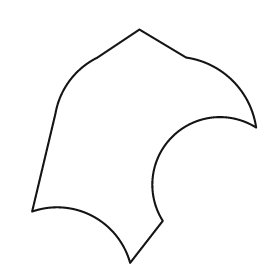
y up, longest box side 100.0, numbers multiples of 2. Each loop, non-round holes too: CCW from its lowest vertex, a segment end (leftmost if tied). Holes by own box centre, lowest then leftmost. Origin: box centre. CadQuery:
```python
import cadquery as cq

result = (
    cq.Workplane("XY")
    .moveTo(-6.0, -50.0)
    .lineTo(8.0, -32.0)
    .threePointArc((12.0, 4.0), (48.0, 8.0))
    .threePointArc((38.0, 28.0), (18.0, 38.0))
    .lineTo(-2.0, 50.0)
    .lineTo(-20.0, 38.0)
    .threePointArc((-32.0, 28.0), (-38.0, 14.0))
    .lineTo(-48.0, -28.0)
    .threePointArc((-22.0, -30.0), (-6.0, -50.0))
    .close()
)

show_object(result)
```